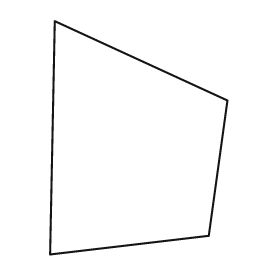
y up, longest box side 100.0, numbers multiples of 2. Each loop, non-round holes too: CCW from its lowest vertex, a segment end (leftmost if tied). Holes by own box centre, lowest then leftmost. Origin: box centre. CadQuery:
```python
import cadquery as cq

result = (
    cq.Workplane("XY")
    .moveTo(-38.0, -50.0)
    .lineTo(30.0, -42.0)
    .lineTo(38.0, 16.0)
    .lineTo(-36.0, 50.0)
    .close()
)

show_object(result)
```